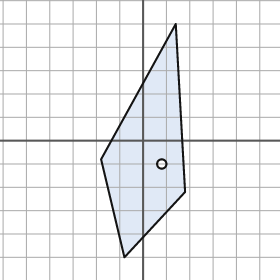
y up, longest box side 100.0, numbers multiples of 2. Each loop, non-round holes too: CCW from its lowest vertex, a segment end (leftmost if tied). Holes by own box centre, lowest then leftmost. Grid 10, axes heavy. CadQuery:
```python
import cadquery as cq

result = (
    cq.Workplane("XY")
    .moveTo(-8.0, -50.0)
    .lineTo(18.0, -22.0)
    .lineTo(14.0, 50.0)
    .lineTo(-18.0, -8.0)
    .close()
    .moveTo(8.0, -10.0)
    .circle(2.0)
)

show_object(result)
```